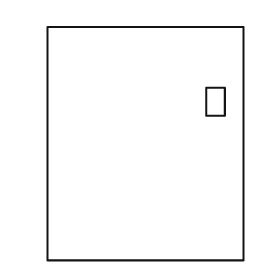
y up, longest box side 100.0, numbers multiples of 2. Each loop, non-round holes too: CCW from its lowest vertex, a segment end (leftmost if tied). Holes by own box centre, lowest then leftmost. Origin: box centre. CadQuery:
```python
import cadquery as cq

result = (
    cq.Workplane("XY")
    .moveTo(-42.0, -50.0)
    .lineTo(42.0, -50.0)
    .lineTo(42.0, 50.0)
    .lineTo(-42.0, 50.0)
    .close()
    .moveTo(26.0, 12.0)
    .lineTo(34.0, 12.0)
    .lineTo(34.0, 24.0)
    .lineTo(26.0, 24.0)
    .close()
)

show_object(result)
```